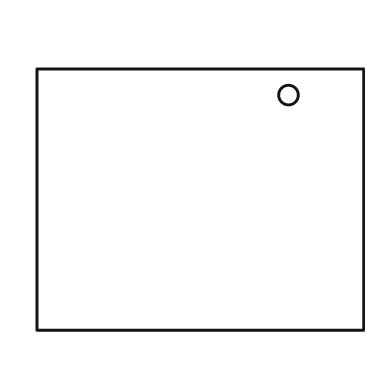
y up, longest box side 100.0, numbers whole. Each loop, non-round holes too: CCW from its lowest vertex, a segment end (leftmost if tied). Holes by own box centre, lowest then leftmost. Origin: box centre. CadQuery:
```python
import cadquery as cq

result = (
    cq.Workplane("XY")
    .moveTo(-50.0, -40.0)
    .lineTo(50.0, -40.0)
    .lineTo(50.0, 40.0)
    .lineTo(-50.0, 40.0)
    .close()
    .moveTo(27.0, 32.0)
    .circle(3.0)
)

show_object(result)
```